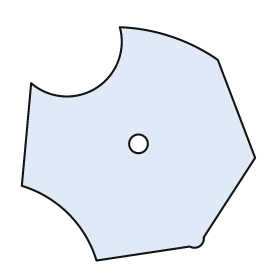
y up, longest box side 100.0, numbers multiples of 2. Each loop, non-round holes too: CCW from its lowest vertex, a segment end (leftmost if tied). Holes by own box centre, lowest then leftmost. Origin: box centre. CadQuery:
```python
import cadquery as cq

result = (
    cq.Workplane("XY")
    .moveTo(-18.0, -50.0)
    .lineTo(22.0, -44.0)
    .threePointArc((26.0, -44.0), (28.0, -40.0))
    .lineTo(50.0, -6.0)
    .lineTo(34.0, 36.0)
    .threePointArc((14.0, 46.0), (-8.0, 50.0))
    .threePointArc((-18.0, 24.0), (-46.0, 26.0))
    .lineTo(-50.0, -18.0)
    .threePointArc((-30.0, -30.0), (-18.0, -50.0))
    .close()
    .moveTo(0.0, 0.0)
    .circle(4.0)
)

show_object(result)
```